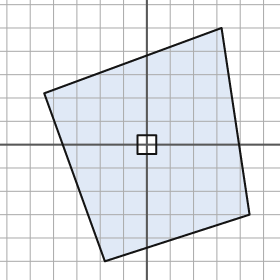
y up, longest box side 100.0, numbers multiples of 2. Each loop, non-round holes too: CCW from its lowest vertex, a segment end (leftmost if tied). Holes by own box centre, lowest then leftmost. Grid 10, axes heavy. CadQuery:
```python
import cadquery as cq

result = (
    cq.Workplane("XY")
    .moveTo(-18.0, -50.0)
    .lineTo(44.0, -30.0)
    .lineTo(32.0, 50.0)
    .lineTo(-44.0, 22.0)
    .close()
    .moveTo(-4.0, -4.0)
    .lineTo(4.0, -4.0)
    .lineTo(4.0, 4.0)
    .lineTo(-4.0, 4.0)
    .close()
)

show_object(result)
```